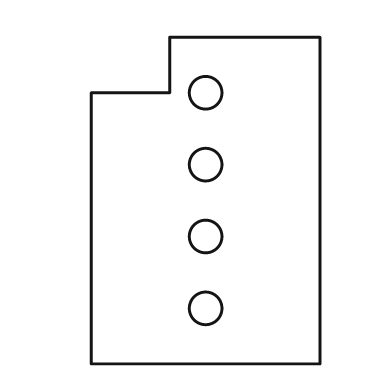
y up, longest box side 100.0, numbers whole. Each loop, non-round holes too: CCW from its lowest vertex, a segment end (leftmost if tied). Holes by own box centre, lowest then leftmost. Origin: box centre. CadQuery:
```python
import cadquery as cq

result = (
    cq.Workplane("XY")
    .moveTo(-35.0, -50.0)
    .lineTo(35.0, -50.0)
    .lineTo(35.0, 50.0)
    .lineTo(-11.0, 50.0)
    .lineTo(-11.0, 33.0)
    .lineTo(-35.0, 33.0)
    .close()
    .moveTo(0.0, -33.0)
    .circle(5.0)
    .moveTo(0.0, -11.0)
    .circle(5.0)
    .moveTo(0.0, 11.0)
    .circle(5.0)
    .moveTo(0.0, 33.0)
    .circle(5.0)
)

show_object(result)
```